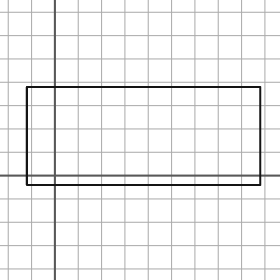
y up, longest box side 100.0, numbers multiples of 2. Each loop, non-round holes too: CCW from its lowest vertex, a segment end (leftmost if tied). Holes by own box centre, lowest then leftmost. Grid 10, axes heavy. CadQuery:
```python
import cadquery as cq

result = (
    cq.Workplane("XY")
    .moveTo(-12.0, -4.0)
    .lineTo(88.0, -4.0)
    .lineTo(88.0, 38.0)
    .lineTo(-12.0, 38.0)
    .close()
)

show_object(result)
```